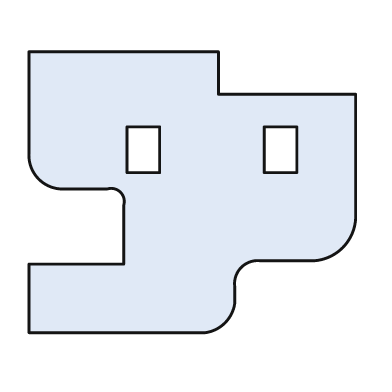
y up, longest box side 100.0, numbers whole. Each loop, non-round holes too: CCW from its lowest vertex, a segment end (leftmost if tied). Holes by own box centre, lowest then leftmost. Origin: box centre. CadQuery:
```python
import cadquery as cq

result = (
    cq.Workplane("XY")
    .moveTo(-50.0, -43.0)
    .lineTo(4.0, -43.0)
    .threePointArc((10.0, -40.0), (13.0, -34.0))
    .lineTo(13.0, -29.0)
    .threePointArc((15.0, -23.0), (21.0, -21.0))
    .lineTo(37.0, -21.0)
    .threePointArc((46.0, -17.0), (50.0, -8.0))
    .lineTo(50.0, 30.0)
    .lineTo(8.0, 30.0)
    .lineTo(8.0, 43.0)
    .lineTo(-50.0, 43.0)
    .lineTo(-50.0, 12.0)
    .threePointArc((-47.0, 4.0), (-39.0, 1.0))
    .lineTo(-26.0, 1.0)
    .threePointArc((-22.0, 0.0), (-21.0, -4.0))
    .lineTo(-21.0, -22.0)
    .lineTo(-50.0, -22.0)
    .close()
    .moveTo(-20.0, 6.0)
    .lineTo(-10.0, 6.0)
    .lineTo(-10.0, 20.0)
    .lineTo(-20.0, 20.0)
    .close()
    .moveTo(22.0, 6.0)
    .lineTo(32.0, 6.0)
    .lineTo(32.0, 20.0)
    .lineTo(22.0, 20.0)
    .close()
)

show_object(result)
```